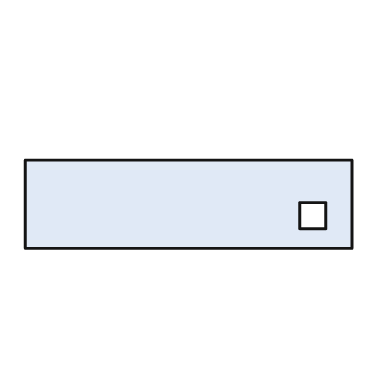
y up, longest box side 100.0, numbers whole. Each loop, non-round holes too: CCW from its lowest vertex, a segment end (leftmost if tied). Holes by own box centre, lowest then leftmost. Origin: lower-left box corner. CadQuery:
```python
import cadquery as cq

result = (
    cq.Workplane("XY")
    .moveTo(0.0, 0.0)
    .lineTo(100.0, 0.0)
    .lineTo(100.0, 27.0)
    .lineTo(0.0, 27.0)
    .close()
    .moveTo(84.0, 6.0)
    .lineTo(92.0, 6.0)
    .lineTo(92.0, 14.0)
    .lineTo(84.0, 14.0)
    .close()
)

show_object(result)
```